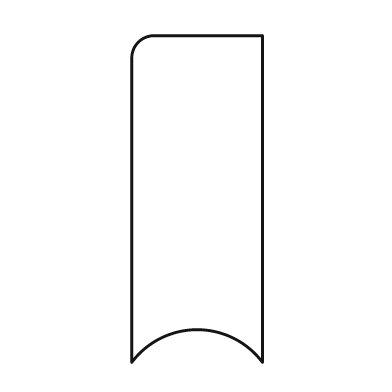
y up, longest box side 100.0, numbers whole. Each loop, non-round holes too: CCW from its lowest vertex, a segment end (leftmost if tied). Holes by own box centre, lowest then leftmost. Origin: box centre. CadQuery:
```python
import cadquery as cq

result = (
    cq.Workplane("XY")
    .moveTo(-20.0, -50.0)
    .threePointArc((0.0, -40.0), (20.0, -50.0))
    .lineTo(20.0, 50.0)
    .lineTo(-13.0, 50.0)
    .threePointArc((-18.0, 48.0), (-20.0, 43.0))
    .close()
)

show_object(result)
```